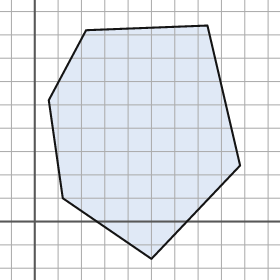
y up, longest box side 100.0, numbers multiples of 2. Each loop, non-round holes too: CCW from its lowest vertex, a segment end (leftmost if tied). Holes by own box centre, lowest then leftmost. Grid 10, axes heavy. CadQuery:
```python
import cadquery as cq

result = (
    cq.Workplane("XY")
    .moveTo(50.0, -16.0)
    .lineTo(88.0, 24.0)
    .lineTo(74.0, 84.0)
    .lineTo(22.0, 82.0)
    .lineTo(6.0, 52.0)
    .lineTo(12.0, 10.0)
    .close()
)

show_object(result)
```